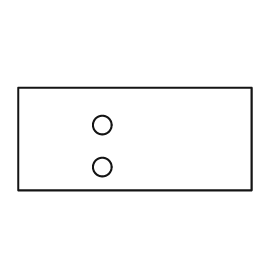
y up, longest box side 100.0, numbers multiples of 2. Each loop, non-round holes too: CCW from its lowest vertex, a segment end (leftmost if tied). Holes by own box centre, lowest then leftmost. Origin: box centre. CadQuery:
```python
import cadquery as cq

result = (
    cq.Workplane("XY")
    .moveTo(-50.0, -22.0)
    .lineTo(50.0, -22.0)
    .lineTo(50.0, 22.0)
    .lineTo(-50.0, 22.0)
    .close()
    .moveTo(-14.0, -12.0)
    .circle(4.0)
    .moveTo(-14.0, 6.0)
    .circle(4.0)
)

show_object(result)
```